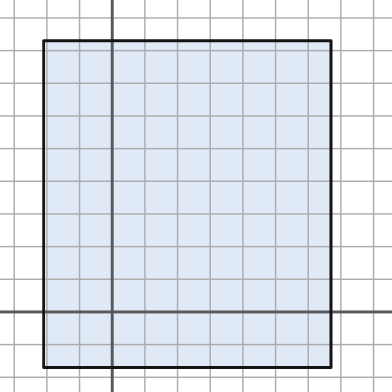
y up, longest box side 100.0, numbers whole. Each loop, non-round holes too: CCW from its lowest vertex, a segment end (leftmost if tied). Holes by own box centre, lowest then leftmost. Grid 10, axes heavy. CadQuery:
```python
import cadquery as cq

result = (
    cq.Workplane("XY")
    .moveTo(-21.0, -17.0)
    .lineTo(67.0, -17.0)
    .lineTo(67.0, 83.0)
    .lineTo(-21.0, 83.0)
    .close()
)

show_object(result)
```